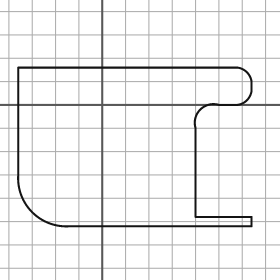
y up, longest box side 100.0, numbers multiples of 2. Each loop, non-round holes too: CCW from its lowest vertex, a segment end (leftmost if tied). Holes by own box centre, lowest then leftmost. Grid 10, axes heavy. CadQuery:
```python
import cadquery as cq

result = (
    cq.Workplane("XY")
    .moveTo(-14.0, -52.0)
    .lineTo(64.0, -52.0)
    .lineTo(64.0, -48.0)
    .lineTo(40.0, -48.0)
    .lineTo(40.0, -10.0)
    .threePointArc((42.0, -2.0), (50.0, 0.0))
    .lineTo(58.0, 0.0)
    .threePointArc((62.0, 2.0), (64.0, 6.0))
    .lineTo(64.0, 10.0)
    .threePointArc((62.0, 14.0), (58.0, 16.0))
    .lineTo(-36.0, 16.0)
    .lineTo(-36.0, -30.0)
    .threePointArc((-30.0, -46.0), (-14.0, -52.0))
    .close()
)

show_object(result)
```